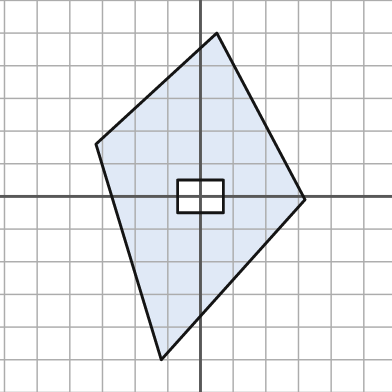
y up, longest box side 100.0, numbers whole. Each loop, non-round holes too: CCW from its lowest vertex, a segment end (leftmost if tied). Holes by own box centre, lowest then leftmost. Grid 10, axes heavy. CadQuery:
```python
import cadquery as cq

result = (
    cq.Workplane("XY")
    .moveTo(-12.0, -50.0)
    .lineTo(32.0, -1.0)
    .lineTo(5.0, 50.0)
    .lineTo(-32.0, 16.0)
    .close()
    .moveTo(-7.0, -5.0)
    .lineTo(7.0, -5.0)
    .lineTo(7.0, 5.0)
    .lineTo(-7.0, 5.0)
    .close()
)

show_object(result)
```